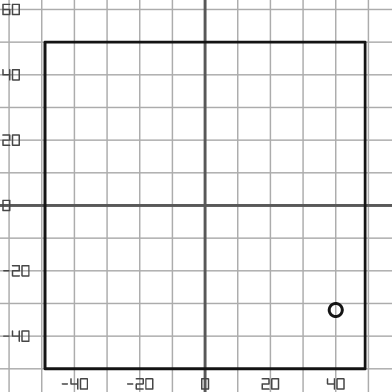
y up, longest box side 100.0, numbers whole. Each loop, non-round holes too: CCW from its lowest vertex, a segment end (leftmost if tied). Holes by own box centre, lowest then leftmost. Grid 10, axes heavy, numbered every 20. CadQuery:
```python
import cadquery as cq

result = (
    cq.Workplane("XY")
    .moveTo(-49.0, -50.0)
    .lineTo(49.0, -50.0)
    .lineTo(49.0, 50.0)
    .lineTo(-49.0, 50.0)
    .close()
    .moveTo(40.0, -32.0)
    .circle(2.0)
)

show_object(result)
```